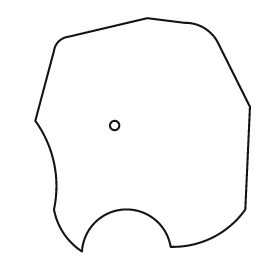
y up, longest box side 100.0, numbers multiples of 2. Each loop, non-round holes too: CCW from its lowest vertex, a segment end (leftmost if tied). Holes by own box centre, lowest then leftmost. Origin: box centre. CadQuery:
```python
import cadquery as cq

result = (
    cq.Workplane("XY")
    .moveTo(-26.0, -50.0)
    .threePointArc((-8.0, -32.0), (12.0, -48.0))
    .threePointArc((30.0, -44.0), (44.0, -32.0))
    .lineTo(46.0, 12.0)
    .lineTo(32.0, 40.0)
    .threePointArc((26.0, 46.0), (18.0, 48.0))
    .lineTo(2.0, 50.0)
    .lineTo(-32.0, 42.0)
    .threePointArc((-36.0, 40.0), (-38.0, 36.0))
    .lineTo(-46.0, 6.0)
    .threePointArc((-38.0, -12.0), (-38.0, -32.0))
    .threePointArc((-34.0, -42.0), (-26.0, -50.0))
    .close()
    .moveTo(-12.0, 4.0)
    .circle(2.0)
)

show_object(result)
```